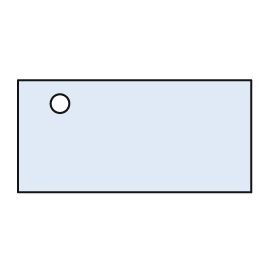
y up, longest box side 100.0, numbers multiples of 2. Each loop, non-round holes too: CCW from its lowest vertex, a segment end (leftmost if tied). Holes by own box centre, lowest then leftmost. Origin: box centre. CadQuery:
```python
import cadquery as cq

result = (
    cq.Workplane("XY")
    .moveTo(-50.0, -24.0)
    .lineTo(50.0, -24.0)
    .lineTo(50.0, 24.0)
    .lineTo(-50.0, 24.0)
    .close()
    .moveTo(-32.0, 14.0)
    .circle(4.0)
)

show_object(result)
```